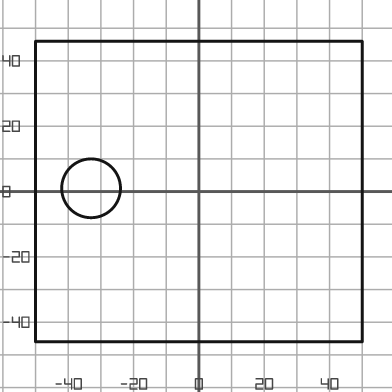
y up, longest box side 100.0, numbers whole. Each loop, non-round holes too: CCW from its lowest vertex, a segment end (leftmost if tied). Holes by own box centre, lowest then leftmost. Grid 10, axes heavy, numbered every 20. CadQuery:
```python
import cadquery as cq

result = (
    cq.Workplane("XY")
    .moveTo(-50.0, -46.0)
    .lineTo(50.0, -46.0)
    .lineTo(50.0, 46.0)
    .lineTo(-50.0, 46.0)
    .close()
    .moveTo(-33.0, 1.0)
    .circle(9.0)
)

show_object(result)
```